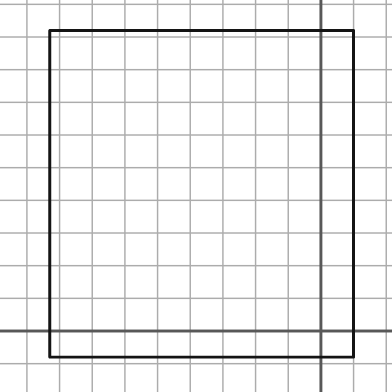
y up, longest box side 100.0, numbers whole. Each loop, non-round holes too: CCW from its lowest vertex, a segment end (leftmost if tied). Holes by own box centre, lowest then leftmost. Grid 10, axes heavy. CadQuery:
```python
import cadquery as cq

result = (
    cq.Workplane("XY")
    .moveTo(-83.0, -8.0)
    .lineTo(10.0, -8.0)
    .lineTo(10.0, 92.0)
    .lineTo(-83.0, 92.0)
    .close()
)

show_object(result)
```